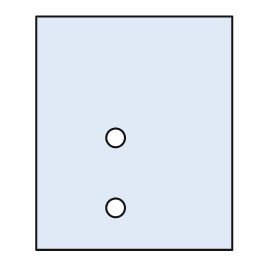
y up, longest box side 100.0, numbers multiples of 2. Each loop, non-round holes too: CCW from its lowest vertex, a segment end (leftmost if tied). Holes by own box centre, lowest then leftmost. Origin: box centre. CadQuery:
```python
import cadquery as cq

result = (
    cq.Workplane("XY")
    .moveTo(-42.0, -50.0)
    .lineTo(42.0, -50.0)
    .lineTo(42.0, 50.0)
    .lineTo(-42.0, 50.0)
    .close()
    .moveTo(-8.0, -32.0)
    .circle(4.0)
    .moveTo(-8.0, -2.0)
    .circle(4.0)
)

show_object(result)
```